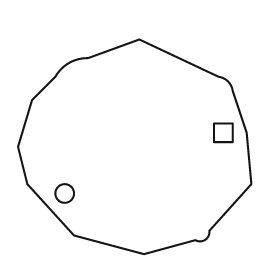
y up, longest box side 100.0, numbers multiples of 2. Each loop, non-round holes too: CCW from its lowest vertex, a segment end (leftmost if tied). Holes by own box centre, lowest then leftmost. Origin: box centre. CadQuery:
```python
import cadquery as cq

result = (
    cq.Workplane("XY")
    .moveTo(4.0, -46.0)
    .lineTo(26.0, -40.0)
    .threePointArc((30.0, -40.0), (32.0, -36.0))
    .lineTo(50.0, -16.0)
    .lineTo(48.0, 6.0)
    .lineTo(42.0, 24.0)
    .threePointArc((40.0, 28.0), (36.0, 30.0))
    .lineTo(2.0, 46.0)
    .lineTo(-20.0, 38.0)
    .threePointArc((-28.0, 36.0), (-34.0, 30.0))
    .lineTo(-44.0, 20.0)
    .lineTo(-50.0, 0.0)
    .lineTo(-46.0, -16.0)
    .lineTo(-26.0, -38.0)
    .close()
    .moveTo(-30.0, -20.0)
    .circle(4.0)
    .moveTo(34.0, 2.0)
    .lineTo(42.0, 2.0)
    .lineTo(42.0, 10.0)
    .lineTo(34.0, 10.0)
    .close()
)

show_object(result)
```